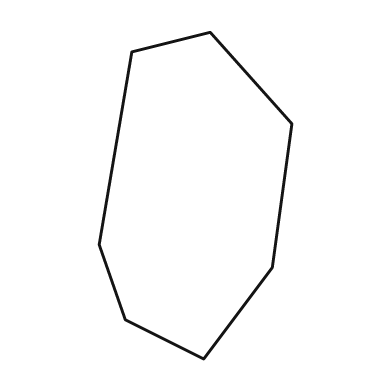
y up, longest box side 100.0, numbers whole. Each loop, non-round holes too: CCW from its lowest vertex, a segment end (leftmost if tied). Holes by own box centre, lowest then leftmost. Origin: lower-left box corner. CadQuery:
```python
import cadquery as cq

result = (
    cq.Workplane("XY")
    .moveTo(32.0, 0.0)
    .lineTo(53.0, 28.0)
    .lineTo(59.0, 72.0)
    .lineTo(34.0, 100.0)
    .lineTo(10.0, 94.0)
    .lineTo(0.0, 35.0)
    .lineTo(8.0, 12.0)
    .close()
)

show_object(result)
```